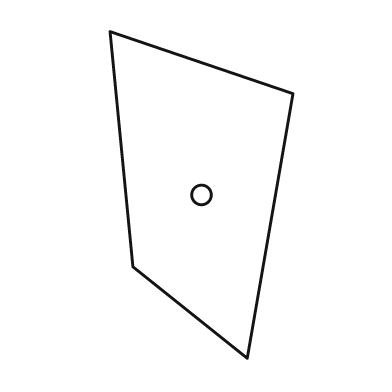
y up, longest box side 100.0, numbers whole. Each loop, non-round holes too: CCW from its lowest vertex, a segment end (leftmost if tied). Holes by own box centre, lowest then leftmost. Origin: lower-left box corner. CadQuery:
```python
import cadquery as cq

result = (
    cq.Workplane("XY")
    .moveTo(42.0, 0.0)
    .lineTo(56.0, 81.0)
    .lineTo(0.0, 100.0)
    .lineTo(7.0, 28.0)
    .close()
    .moveTo(28.0, 50.0)
    .circle(3.0)
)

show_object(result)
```